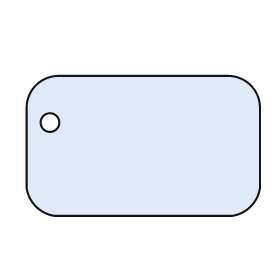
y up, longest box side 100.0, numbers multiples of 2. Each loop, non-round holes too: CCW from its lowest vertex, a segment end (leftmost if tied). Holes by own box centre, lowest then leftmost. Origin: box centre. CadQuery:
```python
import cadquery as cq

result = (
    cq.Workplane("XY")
    .moveTo(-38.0, -30.0)
    .lineTo(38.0, -30.0)
    .threePointArc((46.0, -26.0), (50.0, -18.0))
    .lineTo(50.0, 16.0)
    .threePointArc((46.0, 26.0), (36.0, 30.0))
    .lineTo(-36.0, 30.0)
    .threePointArc((-46.0, 26.0), (-50.0, 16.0))
    .lineTo(-50.0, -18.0)
    .threePointArc((-46.0, -26.0), (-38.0, -30.0))
    .close()
    .moveTo(-40.0, 10.0)
    .circle(4.0)
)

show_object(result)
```